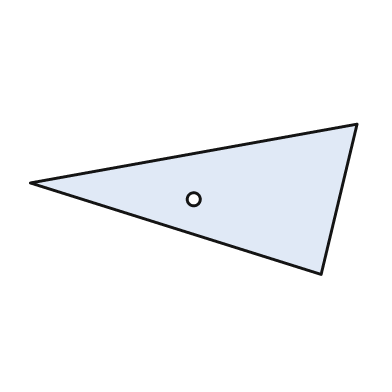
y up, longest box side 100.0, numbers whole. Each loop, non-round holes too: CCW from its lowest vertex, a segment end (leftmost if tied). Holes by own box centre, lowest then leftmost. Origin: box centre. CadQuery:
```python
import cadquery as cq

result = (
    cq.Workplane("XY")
    .moveTo(39.0, -23.0)
    .lineTo(50.0, 23.0)
    .lineTo(-50.0, 5.0)
    .close()
    .moveTo(0.0, 0.0)
    .circle(2.0)
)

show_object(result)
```